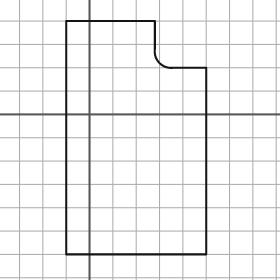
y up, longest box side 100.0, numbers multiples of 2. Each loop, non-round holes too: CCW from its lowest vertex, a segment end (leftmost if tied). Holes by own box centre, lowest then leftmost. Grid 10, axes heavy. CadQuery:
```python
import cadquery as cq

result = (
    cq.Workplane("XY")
    .moveTo(-10.0, -60.0)
    .lineTo(50.0, -60.0)
    .lineTo(50.0, 20.0)
    .lineTo(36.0, 20.0)
    .threePointArc((30.0, 22.0), (28.0, 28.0))
    .lineTo(28.0, 40.0)
    .lineTo(-10.0, 40.0)
    .close()
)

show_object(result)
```